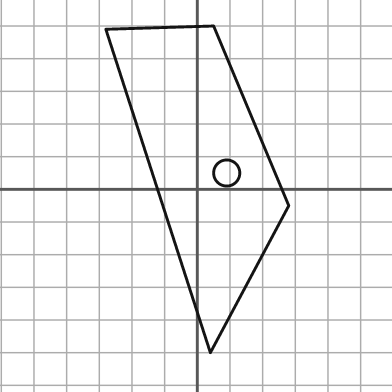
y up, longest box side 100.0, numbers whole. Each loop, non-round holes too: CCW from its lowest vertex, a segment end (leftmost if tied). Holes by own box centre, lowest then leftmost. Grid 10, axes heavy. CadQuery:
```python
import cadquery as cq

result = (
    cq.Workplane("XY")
    .moveTo(4.0, -50.0)
    .lineTo(28.0, -5.0)
    .lineTo(5.0, 50.0)
    .lineTo(-28.0, 49.0)
    .close()
    .moveTo(9.0, 5.0)
    .circle(4.0)
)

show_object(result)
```